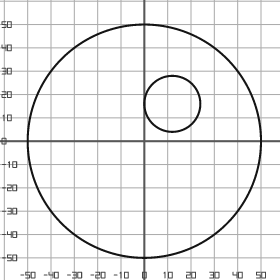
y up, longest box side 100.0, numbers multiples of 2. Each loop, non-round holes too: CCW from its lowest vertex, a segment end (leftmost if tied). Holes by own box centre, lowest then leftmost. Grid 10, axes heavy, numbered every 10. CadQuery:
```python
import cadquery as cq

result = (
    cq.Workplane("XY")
    .moveTo(0.0, 0.0)
    .circle(50.0)
    .moveTo(12.0, 16.0)
    .circle(12.0)
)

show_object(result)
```